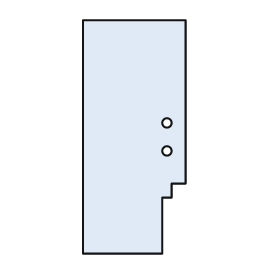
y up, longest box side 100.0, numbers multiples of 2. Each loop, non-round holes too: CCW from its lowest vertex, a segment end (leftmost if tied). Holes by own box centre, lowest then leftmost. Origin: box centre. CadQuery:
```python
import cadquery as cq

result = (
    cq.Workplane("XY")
    .moveTo(-22.0, -50.0)
    .lineTo(12.0, -50.0)
    .lineTo(12.0, -26.0)
    .lineTo(16.0, -26.0)
    .lineTo(16.0, -20.0)
    .lineTo(22.0, -20.0)
    .lineTo(22.0, 50.0)
    .lineTo(-22.0, 50.0)
    .close()
    .moveTo(14.0, -6.0)
    .circle(2.0)
    .moveTo(14.0, 6.0)
    .circle(2.0)
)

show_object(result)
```